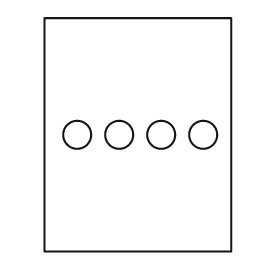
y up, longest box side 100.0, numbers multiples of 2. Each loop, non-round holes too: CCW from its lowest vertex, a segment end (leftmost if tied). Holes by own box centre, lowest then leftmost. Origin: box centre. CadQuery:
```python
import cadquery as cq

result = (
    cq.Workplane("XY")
    .moveTo(-40.0, -50.0)
    .lineTo(40.0, -50.0)
    .lineTo(40.0, 50.0)
    .lineTo(-40.0, 50.0)
    .close()
    .moveTo(-26.0, 0.0)
    .circle(6.0)
    .moveTo(-8.0, 0.0)
    .circle(6.0)
    .moveTo(10.0, 0.0)
    .circle(6.0)
    .moveTo(28.0, 0.0)
    .circle(6.0)
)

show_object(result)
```